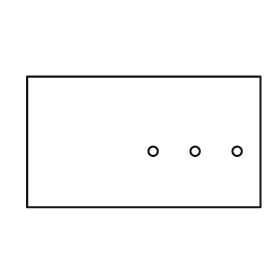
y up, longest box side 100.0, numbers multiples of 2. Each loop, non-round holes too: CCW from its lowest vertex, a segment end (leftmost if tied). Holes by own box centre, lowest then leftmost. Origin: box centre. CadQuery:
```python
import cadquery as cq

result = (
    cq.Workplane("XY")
    .moveTo(-50.0, -28.0)
    .lineTo(50.0, -28.0)
    .lineTo(50.0, 28.0)
    .lineTo(-50.0, 28.0)
    .close()
    .moveTo(4.0, -4.0)
    .circle(2.0)
    .moveTo(22.0, -4.0)
    .circle(2.0)
    .moveTo(40.0, -4.0)
    .circle(2.0)
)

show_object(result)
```